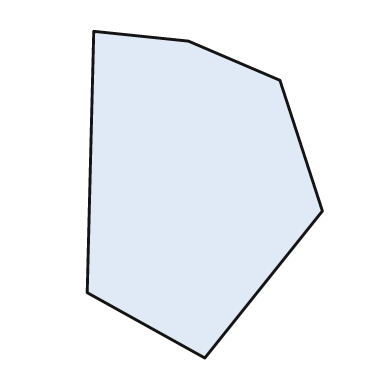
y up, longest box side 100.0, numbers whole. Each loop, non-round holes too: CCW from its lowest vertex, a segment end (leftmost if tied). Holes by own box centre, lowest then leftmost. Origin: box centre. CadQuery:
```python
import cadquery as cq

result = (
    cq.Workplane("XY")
    .moveTo(0.0, -50.0)
    .lineTo(36.0, -5.0)
    .lineTo(23.0, 35.0)
    .lineTo(-5.0, 47.0)
    .lineTo(-34.0, 50.0)
    .lineTo(-36.0, -30.0)
    .close()
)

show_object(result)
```